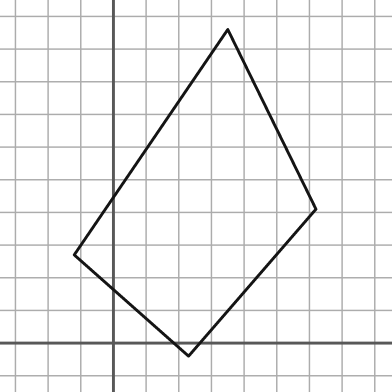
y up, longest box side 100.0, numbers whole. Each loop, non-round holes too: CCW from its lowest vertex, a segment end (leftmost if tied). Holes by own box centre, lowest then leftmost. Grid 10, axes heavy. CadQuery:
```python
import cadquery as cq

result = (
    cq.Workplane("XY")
    .moveTo(23.0, -4.0)
    .lineTo(62.0, 41.0)
    .lineTo(35.0, 96.0)
    .lineTo(-12.0, 27.0)
    .close()
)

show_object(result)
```